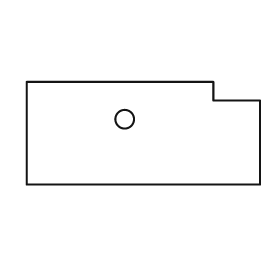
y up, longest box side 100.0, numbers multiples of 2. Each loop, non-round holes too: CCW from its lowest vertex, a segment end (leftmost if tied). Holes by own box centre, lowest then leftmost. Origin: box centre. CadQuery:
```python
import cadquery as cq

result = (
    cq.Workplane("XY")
    .moveTo(-50.0, -22.0)
    .lineTo(50.0, -22.0)
    .lineTo(50.0, 14.0)
    .lineTo(30.0, 14.0)
    .lineTo(30.0, 22.0)
    .lineTo(-50.0, 22.0)
    .close()
    .moveTo(-8.0, 6.0)
    .circle(4.0)
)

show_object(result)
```